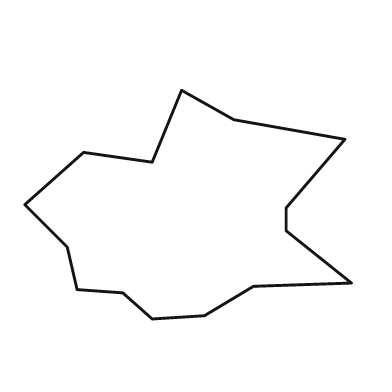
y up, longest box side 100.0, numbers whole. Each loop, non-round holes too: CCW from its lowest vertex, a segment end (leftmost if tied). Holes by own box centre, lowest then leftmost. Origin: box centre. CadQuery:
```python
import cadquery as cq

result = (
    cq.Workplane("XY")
    .moveTo(-11.0, -35.0)
    .lineTo(5.0, -34.0)
    .lineTo(20.0, -25.0)
    .lineTo(50.0, -24.0)
    .lineTo(30.0, -8.0)
    .lineTo(30.0, -1.0)
    .lineTo(48.0, 20.0)
    .lineTo(14.0, 26.0)
    .lineTo(-2.0, 35.0)
    .lineTo(-11.0, 13.0)
    .lineTo(-32.0, 16.0)
    .lineTo(-50.0, 0.0)
    .lineTo(-37.0, -13.0)
    .lineTo(-34.0, -26.0)
    .lineTo(-20.0, -27.0)
    .close()
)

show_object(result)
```